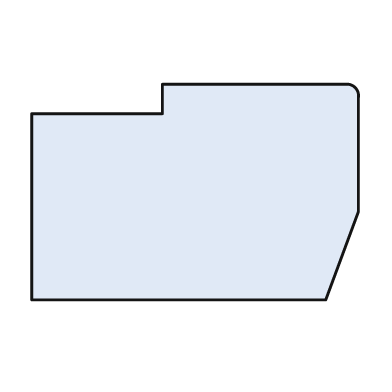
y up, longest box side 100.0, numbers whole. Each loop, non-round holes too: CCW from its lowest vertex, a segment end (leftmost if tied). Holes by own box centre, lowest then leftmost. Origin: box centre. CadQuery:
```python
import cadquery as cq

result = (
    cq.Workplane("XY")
    .moveTo(-50.0, -33.0)
    .lineTo(40.0, -33.0)
    .lineTo(50.0, -6.0)
    .lineTo(50.0, 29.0)
    .threePointArc((49.0, 32.0), (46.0, 33.0))
    .lineTo(-10.0, 33.0)
    .lineTo(-10.0, 24.0)
    .lineTo(-50.0, 24.0)
    .close()
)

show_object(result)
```